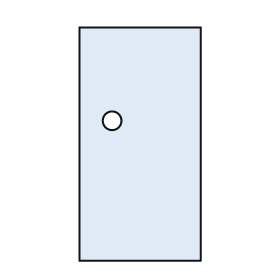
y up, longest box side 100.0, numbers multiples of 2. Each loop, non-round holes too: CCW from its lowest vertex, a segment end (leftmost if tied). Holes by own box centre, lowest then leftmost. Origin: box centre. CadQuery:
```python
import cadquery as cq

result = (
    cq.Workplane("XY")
    .moveTo(-26.0, -50.0)
    .lineTo(26.0, -50.0)
    .lineTo(26.0, 50.0)
    .lineTo(-26.0, 50.0)
    .close()
    .moveTo(-12.0, 10.0)
    .circle(4.0)
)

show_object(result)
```